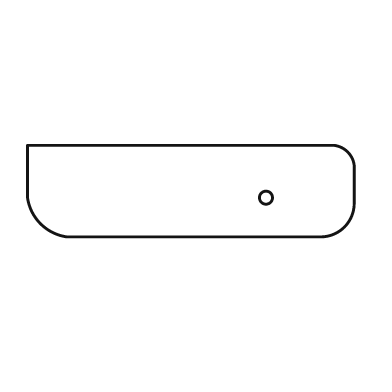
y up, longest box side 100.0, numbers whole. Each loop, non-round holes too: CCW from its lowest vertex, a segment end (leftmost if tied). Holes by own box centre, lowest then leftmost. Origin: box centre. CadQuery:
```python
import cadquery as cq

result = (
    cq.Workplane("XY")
    .moveTo(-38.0, -14.0)
    .lineTo(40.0, -14.0)
    .threePointArc((47.0, -11.0), (50.0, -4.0))
    .lineTo(50.0, 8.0)
    .threePointArc((48.0, 12.0), (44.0, 14.0))
    .lineTo(-50.0, 14.0)
    .lineTo(-50.0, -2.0)
    .threePointArc((-46.0, -10.0), (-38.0, -14.0))
    .close()
    .moveTo(23.0, -2.0)
    .circle(2.0)
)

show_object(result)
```